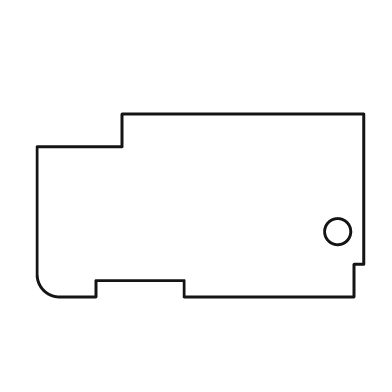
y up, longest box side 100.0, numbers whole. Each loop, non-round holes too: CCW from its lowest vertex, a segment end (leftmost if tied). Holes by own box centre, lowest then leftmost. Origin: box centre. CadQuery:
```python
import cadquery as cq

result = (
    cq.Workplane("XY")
    .moveTo(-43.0, -28.0)
    .lineTo(-32.0, -28.0)
    .lineTo(-32.0, -23.0)
    .lineTo(-5.0, -23.0)
    .lineTo(-5.0, -28.0)
    .lineTo(47.0, -28.0)
    .lineTo(47.0, -18.0)
    .lineTo(50.0, -18.0)
    .lineTo(50.0, 28.0)
    .lineTo(-24.0, 28.0)
    .lineTo(-24.0, 18.0)
    .lineTo(-50.0, 18.0)
    .lineTo(-50.0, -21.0)
    .threePointArc((-48.0, -26.0), (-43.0, -28.0))
    .close()
    .moveTo(42.0, -8.0)
    .circle(4.0)
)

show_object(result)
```